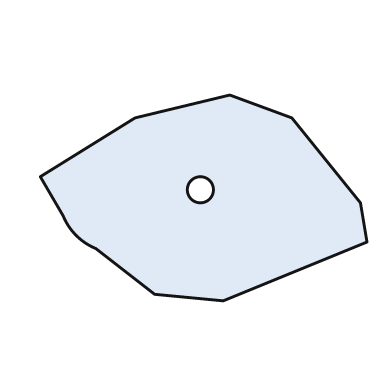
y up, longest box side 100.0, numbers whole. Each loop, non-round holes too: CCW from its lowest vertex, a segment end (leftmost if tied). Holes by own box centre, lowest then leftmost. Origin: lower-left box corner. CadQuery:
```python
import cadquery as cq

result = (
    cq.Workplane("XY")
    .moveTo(56.0, 0.0)
    .lineTo(100.0, 18.0)
    .lineTo(98.0, 30.0)
    .lineTo(77.0, 56.0)
    .lineTo(58.0, 63.0)
    .lineTo(29.0, 56.0)
    .lineTo(0.0, 38.0)
    .lineTo(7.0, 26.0)
    .threePointArc((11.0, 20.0), (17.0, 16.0))
    .lineTo(35.0, 2.0)
    .close()
    .moveTo(49.0, 34.0)
    .circle(4.0)
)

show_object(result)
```